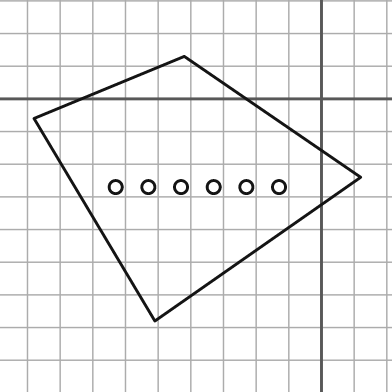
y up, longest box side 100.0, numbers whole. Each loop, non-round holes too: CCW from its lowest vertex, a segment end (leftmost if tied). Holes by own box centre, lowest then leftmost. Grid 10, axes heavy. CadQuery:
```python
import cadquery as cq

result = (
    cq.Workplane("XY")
    .moveTo(-51.0, -68.0)
    .lineTo(12.0, -24.0)
    .lineTo(-42.0, 13.0)
    .lineTo(-88.0, -6.0)
    .close()
    .moveTo(-63.0, -27.0)
    .circle(2.0)
    .moveTo(-53.0, -27.0)
    .circle(2.0)
    .moveTo(-43.0, -27.0)
    .circle(2.0)
    .moveTo(-33.0, -27.0)
    .circle(2.0)
    .moveTo(-23.0, -27.0)
    .circle(2.0)
    .moveTo(-13.0, -27.0)
    .circle(2.0)
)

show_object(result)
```